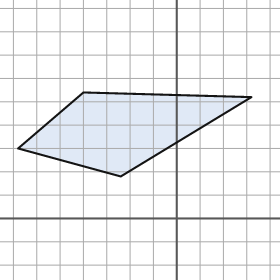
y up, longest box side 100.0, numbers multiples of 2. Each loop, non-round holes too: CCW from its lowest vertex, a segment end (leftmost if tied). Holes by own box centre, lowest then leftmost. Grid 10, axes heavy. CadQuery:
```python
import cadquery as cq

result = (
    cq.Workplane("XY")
    .moveTo(-24.0, 18.0)
    .lineTo(32.0, 52.0)
    .lineTo(-40.0, 54.0)
    .lineTo(-68.0, 30.0)
    .close()
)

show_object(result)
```